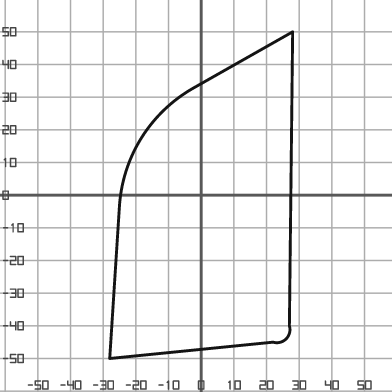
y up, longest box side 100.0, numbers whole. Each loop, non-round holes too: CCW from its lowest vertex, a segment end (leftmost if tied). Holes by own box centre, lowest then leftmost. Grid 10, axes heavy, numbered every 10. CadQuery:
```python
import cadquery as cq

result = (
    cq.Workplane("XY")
    .moveTo(-28.0, -50.0)
    .lineTo(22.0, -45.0)
    .threePointArc((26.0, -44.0), (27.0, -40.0))
    .lineTo(28.0, 50.0)
    .lineTo(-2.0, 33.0)
    .threePointArc((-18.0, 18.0), (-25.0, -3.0))
    .close()
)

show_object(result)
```